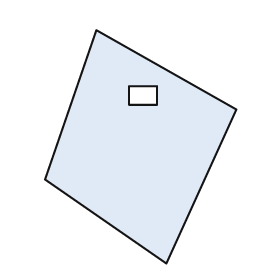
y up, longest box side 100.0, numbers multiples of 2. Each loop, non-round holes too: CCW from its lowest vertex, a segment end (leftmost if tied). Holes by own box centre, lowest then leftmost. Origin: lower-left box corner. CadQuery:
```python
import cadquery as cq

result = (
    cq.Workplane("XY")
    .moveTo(52.0, 0.0)
    .lineTo(82.0, 66.0)
    .lineTo(22.0, 100.0)
    .lineTo(0.0, 36.0)
    .close()
    .moveTo(36.0, 68.0)
    .lineTo(48.0, 68.0)
    .lineTo(48.0, 76.0)
    .lineTo(36.0, 76.0)
    .close()
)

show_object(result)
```